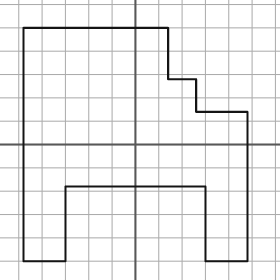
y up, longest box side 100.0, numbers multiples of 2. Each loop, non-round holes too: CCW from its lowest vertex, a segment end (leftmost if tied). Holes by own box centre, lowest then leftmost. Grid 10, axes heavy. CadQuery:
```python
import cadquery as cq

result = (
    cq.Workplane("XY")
    .moveTo(-48.0, -50.0)
    .lineTo(-30.0, -50.0)
    .lineTo(-30.0, -18.0)
    .lineTo(30.0, -18.0)
    .lineTo(30.0, -50.0)
    .lineTo(48.0, -50.0)
    .lineTo(48.0, 14.0)
    .lineTo(26.0, 14.0)
    .lineTo(26.0, 28.0)
    .lineTo(14.0, 28.0)
    .lineTo(14.0, 50.0)
    .lineTo(-48.0, 50.0)
    .close()
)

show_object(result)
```